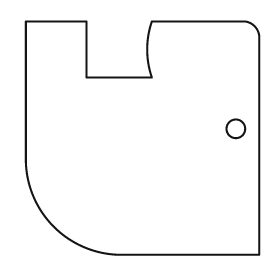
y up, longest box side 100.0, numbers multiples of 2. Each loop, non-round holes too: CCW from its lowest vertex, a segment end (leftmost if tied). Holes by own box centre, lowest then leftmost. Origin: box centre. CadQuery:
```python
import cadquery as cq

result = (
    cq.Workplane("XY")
    .moveTo(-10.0, -50.0)
    .lineTo(50.0, -50.0)
    .lineTo(50.0, 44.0)
    .threePointArc((48.0, 48.0), (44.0, 50.0))
    .lineTo(4.0, 50.0)
    .threePointArc((2.0, 38.0), (4.0, 26.0))
    .lineTo(-24.0, 26.0)
    .lineTo(-24.0, 50.0)
    .lineTo(-50.0, 50.0)
    .lineTo(-50.0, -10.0)
    .threePointArc((-38.0, -38.0), (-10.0, -50.0))
    .close()
    .moveTo(40.0, 4.0)
    .circle(4.0)
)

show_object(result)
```